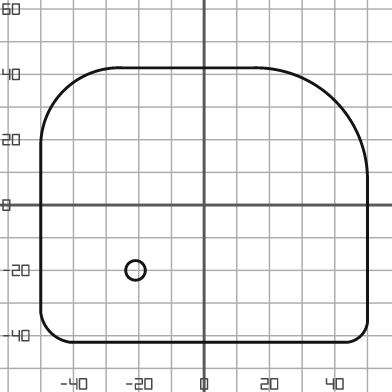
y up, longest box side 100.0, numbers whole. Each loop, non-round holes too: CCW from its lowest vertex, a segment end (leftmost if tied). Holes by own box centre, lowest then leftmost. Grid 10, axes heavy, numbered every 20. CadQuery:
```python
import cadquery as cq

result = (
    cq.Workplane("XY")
    .moveTo(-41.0, -42.0)
    .lineTo(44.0, -42.0)
    .threePointArc((48.0, -40.0), (50.0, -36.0))
    .lineTo(50.0, 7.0)
    .threePointArc((40.0, 32.0), (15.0, 42.0))
    .lineTo(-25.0, 42.0)
    .threePointArc((-43.0, 35.0), (-50.0, 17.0))
    .lineTo(-50.0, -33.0)
    .threePointArc((-47.0, -39.0), (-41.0, -42.0))
    .close()
    .moveTo(-21.0, -20.0)
    .circle(3.0)
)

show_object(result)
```